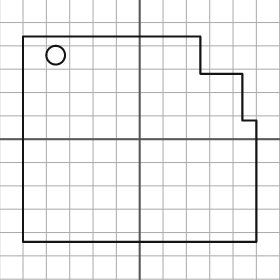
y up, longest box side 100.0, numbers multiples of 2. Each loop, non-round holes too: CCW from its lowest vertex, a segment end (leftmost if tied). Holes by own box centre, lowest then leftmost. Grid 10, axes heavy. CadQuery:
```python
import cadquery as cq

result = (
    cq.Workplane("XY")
    .moveTo(-50.0, -44.0)
    .lineTo(50.0, -44.0)
    .lineTo(50.0, 8.0)
    .lineTo(44.0, 8.0)
    .lineTo(44.0, 28.0)
    .lineTo(26.0, 28.0)
    .lineTo(26.0, 44.0)
    .lineTo(-50.0, 44.0)
    .close()
    .moveTo(-36.0, 36.0)
    .circle(4.0)
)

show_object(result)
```